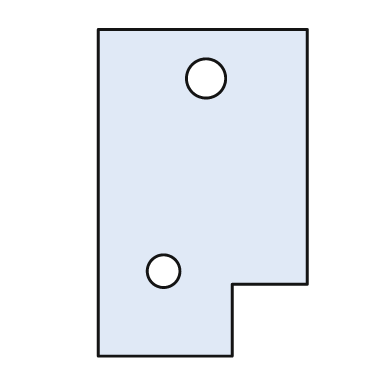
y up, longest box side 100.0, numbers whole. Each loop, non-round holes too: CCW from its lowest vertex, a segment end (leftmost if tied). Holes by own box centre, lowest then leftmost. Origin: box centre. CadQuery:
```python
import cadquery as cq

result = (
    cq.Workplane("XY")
    .moveTo(-32.0, -50.0)
    .lineTo(9.0, -50.0)
    .lineTo(9.0, -28.0)
    .lineTo(32.0, -28.0)
    .lineTo(32.0, 50.0)
    .lineTo(-32.0, 50.0)
    .close()
    .moveTo(-12.0, -24.0)
    .circle(5.0)
    .moveTo(1.0, 35.0)
    .circle(6.0)
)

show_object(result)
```